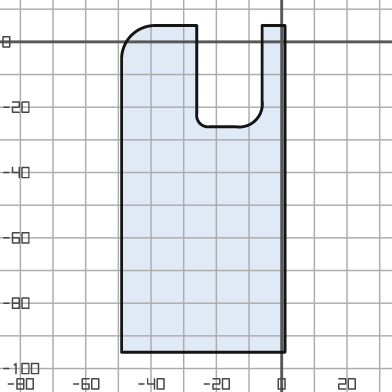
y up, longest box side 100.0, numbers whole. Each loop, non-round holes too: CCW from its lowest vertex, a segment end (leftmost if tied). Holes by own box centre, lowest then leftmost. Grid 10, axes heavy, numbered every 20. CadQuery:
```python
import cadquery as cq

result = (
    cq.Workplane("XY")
    .moveTo(-49.0, -95.0)
    .lineTo(1.0, -95.0)
    .lineTo(1.0, 5.0)
    .lineTo(-6.0, 5.0)
    .lineTo(-6.0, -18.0)
    .threePointArc((-8.0, -24.0), (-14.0, -26.0))
    .lineTo(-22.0, -26.0)
    .threePointArc((-25.0, -25.0), (-26.0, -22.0))
    .lineTo(-26.0, 5.0)
    .lineTo(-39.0, 5.0)
    .threePointArc((-46.0, 2.0), (-49.0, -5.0))
    .close()
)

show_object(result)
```